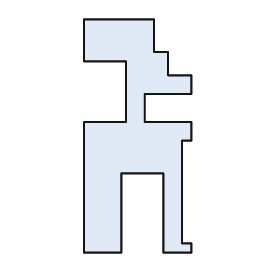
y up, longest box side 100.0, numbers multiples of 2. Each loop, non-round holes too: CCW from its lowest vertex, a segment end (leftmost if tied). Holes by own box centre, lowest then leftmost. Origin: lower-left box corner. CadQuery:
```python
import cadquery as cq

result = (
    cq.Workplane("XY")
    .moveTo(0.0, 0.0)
    .lineTo(16.0, 0.0)
    .lineTo(16.0, 34.0)
    .lineTo(34.0, 34.0)
    .lineTo(34.0, 0.0)
    .lineTo(46.0, 0.0)
    .lineTo(46.0, 4.0)
    .lineTo(42.0, 4.0)
    .lineTo(42.0, 48.0)
    .lineTo(46.0, 48.0)
    .lineTo(46.0, 56.0)
    .lineTo(26.0, 56.0)
    .lineTo(26.0, 68.0)
    .lineTo(46.0, 68.0)
    .lineTo(46.0, 76.0)
    .lineTo(36.0, 76.0)
    .lineTo(36.0, 86.0)
    .lineTo(30.0, 86.0)
    .lineTo(30.0, 100.0)
    .lineTo(0.0, 100.0)
    .lineTo(0.0, 82.0)
    .lineTo(18.0, 82.0)
    .lineTo(18.0, 56.0)
    .lineTo(0.0, 56.0)
    .close()
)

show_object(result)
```